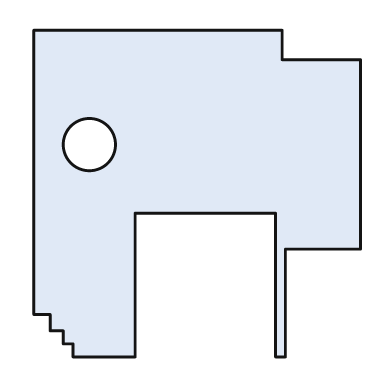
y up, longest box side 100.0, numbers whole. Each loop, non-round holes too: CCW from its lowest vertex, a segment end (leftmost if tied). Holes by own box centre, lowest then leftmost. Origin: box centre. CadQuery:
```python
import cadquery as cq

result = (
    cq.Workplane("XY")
    .moveTo(-38.0, -50.0)
    .lineTo(-19.0, -50.0)
    .lineTo(-19.0, -6.0)
    .lineTo(24.0, -6.0)
    .lineTo(24.0, -50.0)
    .lineTo(27.0, -50.0)
    .lineTo(27.0, -17.0)
    .lineTo(50.0, -17.0)
    .lineTo(50.0, 41.0)
    .lineTo(26.0, 41.0)
    .lineTo(26.0, 50.0)
    .lineTo(-50.0, 50.0)
    .lineTo(-50.0, -37.0)
    .lineTo(-45.0, -37.0)
    .lineTo(-45.0, -42.0)
    .lineTo(-41.0, -42.0)
    .lineTo(-41.0, -46.0)
    .lineTo(-38.0, -46.0)
    .close()
    .moveTo(-33.0, 15.0)
    .circle(8.0)
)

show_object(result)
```